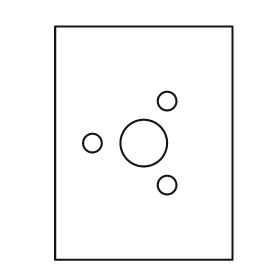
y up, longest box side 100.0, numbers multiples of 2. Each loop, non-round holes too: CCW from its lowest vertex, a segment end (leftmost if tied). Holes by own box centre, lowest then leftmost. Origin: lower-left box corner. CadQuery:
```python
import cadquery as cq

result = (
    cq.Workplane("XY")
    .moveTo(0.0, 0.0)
    .lineTo(76.0, 0.0)
    .lineTo(76.0, 100.0)
    .lineTo(0.0, 100.0)
    .close()
    .moveTo(48.0, 32.0)
    .circle(4.0)
    .moveTo(16.0, 50.0)
    .circle(4.0)
    .moveTo(38.0, 50.0)
    .circle(10.0)
    .moveTo(48.0, 68.0)
    .circle(4.0)
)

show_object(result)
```